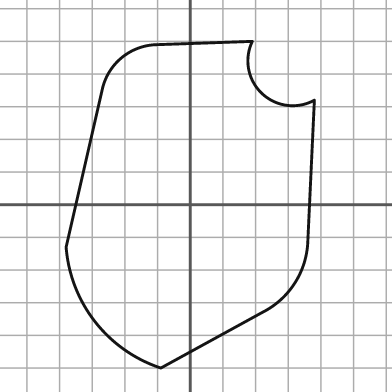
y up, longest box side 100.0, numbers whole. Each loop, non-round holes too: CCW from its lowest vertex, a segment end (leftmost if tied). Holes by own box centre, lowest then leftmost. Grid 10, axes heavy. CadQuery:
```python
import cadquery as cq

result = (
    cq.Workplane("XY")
    .moveTo(-9.0, -50.0)
    .lineTo(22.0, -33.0)
    .threePointArc((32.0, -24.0), (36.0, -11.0))
    .lineTo(38.0, 32.0)
    .threePointArc((22.0, 34.0), (19.0, 50.0))
    .lineTo(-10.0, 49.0)
    .threePointArc((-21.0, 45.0), (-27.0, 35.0))
    .lineTo(-38.0, -13.0)
    .threePointArc((-29.0, -36.0), (-9.0, -50.0))
    .close()
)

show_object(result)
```